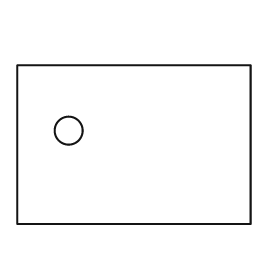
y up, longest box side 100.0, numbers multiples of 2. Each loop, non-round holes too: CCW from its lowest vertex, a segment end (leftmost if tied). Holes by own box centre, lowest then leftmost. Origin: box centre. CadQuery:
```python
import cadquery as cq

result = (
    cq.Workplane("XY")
    .moveTo(-50.0, -34.0)
    .lineTo(50.0, -34.0)
    .lineTo(50.0, 34.0)
    .lineTo(-50.0, 34.0)
    .close()
    .moveTo(-28.0, 6.0)
    .circle(6.0)
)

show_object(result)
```